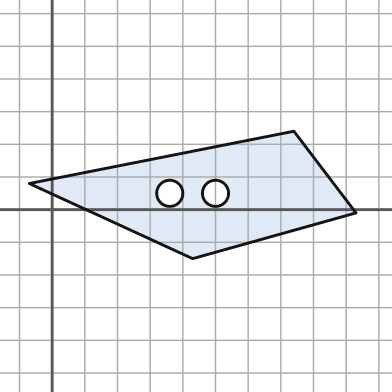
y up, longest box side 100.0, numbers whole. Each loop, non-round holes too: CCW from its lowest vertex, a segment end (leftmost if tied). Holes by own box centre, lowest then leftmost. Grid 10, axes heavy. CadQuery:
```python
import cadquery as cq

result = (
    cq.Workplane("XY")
    .moveTo(43.0, -15.0)
    .lineTo(93.0, -1.0)
    .lineTo(74.0, 24.0)
    .lineTo(-7.0, 8.0)
    .close()
    .moveTo(36.0, 5.0)
    .circle(4.0)
    .moveTo(50.0, 5.0)
    .circle(4.0)
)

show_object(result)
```